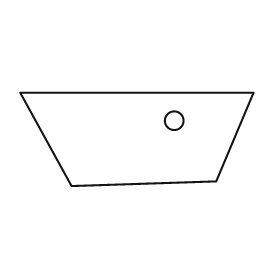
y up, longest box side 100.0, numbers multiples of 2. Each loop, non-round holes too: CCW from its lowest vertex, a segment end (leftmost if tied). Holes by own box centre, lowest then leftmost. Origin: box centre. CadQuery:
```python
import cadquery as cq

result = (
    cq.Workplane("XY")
    .moveTo(-28.0, -20.0)
    .lineTo(34.0, -18.0)
    .lineTo(50.0, 20.0)
    .lineTo(-50.0, 20.0)
    .close()
    .moveTo(16.0, 8.0)
    .circle(4.0)
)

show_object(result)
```